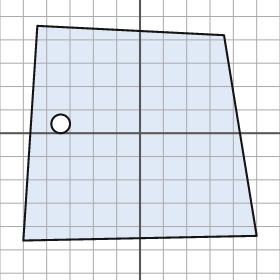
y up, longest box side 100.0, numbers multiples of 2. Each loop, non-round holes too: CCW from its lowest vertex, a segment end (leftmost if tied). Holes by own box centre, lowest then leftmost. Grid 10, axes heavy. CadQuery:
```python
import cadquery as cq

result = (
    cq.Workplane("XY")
    .moveTo(-50.0, -46.0)
    .lineTo(50.0, -44.0)
    .lineTo(36.0, 42.0)
    .lineTo(-44.0, 46.0)
    .close()
    .moveTo(-34.0, 4.0)
    .circle(4.0)
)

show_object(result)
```